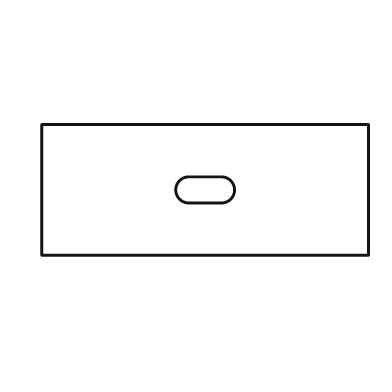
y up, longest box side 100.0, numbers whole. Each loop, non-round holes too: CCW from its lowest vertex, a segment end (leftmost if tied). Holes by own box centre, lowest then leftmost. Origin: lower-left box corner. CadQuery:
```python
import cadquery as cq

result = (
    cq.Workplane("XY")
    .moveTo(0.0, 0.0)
    .lineTo(100.0, 0.0)
    .lineTo(100.0, 40.0)
    .lineTo(0.0, 40.0)
    .close()
    .moveTo(45.0, 16.0)
    .lineTo(55.0, 16.0)
    .threePointArc((59.0, 20.0), (55.0, 24.0))
    .lineTo(45.0, 24.0)
    .threePointArc((41.0, 20.0), (45.0, 16.0))
    .close()
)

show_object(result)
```